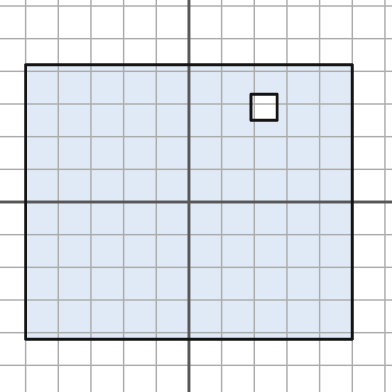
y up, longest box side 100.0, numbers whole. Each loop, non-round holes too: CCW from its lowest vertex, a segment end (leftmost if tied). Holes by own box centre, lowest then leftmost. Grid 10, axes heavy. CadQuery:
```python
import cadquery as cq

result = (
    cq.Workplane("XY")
    .moveTo(-50.0, -42.0)
    .lineTo(50.0, -42.0)
    .lineTo(50.0, 42.0)
    .lineTo(-50.0, 42.0)
    .close()
    .moveTo(19.0, 25.0)
    .lineTo(27.0, 25.0)
    .lineTo(27.0, 33.0)
    .lineTo(19.0, 33.0)
    .close()
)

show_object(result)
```